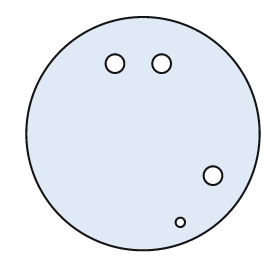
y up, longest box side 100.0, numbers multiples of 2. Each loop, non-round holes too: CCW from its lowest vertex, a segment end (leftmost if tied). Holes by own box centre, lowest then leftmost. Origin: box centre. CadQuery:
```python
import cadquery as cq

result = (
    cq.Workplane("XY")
    .moveTo(0.0, 0.0)
    .circle(50.0)
    .moveTo(16.0, -38.0)
    .circle(2.0)
    .moveTo(30.0, -18.0)
    .circle(4.0)
    .moveTo(-12.0, 30.0)
    .circle(4.0)
    .moveTo(8.0, 30.0)
    .circle(4.0)
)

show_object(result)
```